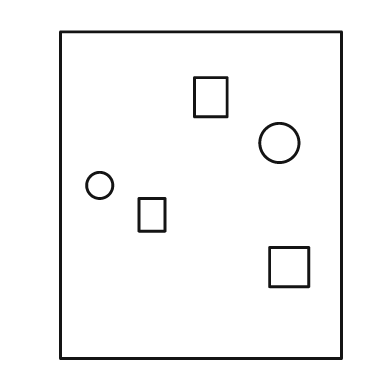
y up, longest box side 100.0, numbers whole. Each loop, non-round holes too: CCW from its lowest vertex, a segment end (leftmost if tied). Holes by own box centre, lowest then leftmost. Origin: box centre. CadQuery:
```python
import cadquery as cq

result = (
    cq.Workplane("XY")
    .moveTo(-43.0, -50.0)
    .lineTo(43.0, -50.0)
    .lineTo(43.0, 50.0)
    .lineTo(-43.0, 50.0)
    .close()
    .moveTo(21.0, -28.0)
    .lineTo(33.0, -28.0)
    .lineTo(33.0, -16.0)
    .lineTo(21.0, -16.0)
    .close()
    .moveTo(-19.0, -11.0)
    .lineTo(-11.0, -11.0)
    .lineTo(-11.0, -1.0)
    .lineTo(-19.0, -1.0)
    .close()
    .moveTo(-31.0, 3.0)
    .circle(4.0)
    .moveTo(24.0, 16.0)
    .circle(6.0)
    .moveTo(-2.0, 24.0)
    .lineTo(8.0, 24.0)
    .lineTo(8.0, 36.0)
    .lineTo(-2.0, 36.0)
    .close()
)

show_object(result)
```